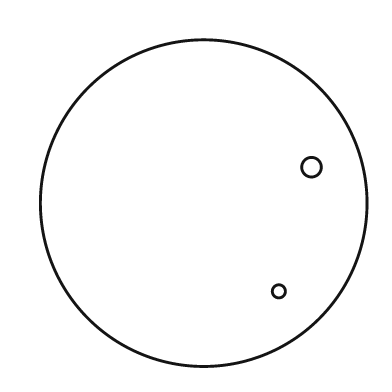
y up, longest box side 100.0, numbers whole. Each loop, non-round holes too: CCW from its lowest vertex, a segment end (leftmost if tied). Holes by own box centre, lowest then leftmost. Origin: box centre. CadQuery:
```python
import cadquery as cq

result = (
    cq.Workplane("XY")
    .moveTo(0.0, 0.0)
    .circle(50.0)
    .moveTo(23.0, -27.0)
    .circle(2.0)
    .moveTo(33.0, 11.0)
    .circle(3.0)
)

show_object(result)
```